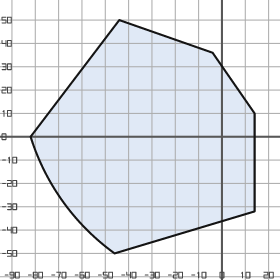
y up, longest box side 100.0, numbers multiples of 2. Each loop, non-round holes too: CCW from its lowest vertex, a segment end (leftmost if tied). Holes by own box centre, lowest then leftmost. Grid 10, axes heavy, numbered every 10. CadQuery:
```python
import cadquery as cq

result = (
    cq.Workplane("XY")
    .moveTo(-46.0, -50.0)
    .lineTo(14.0, -32.0)
    .lineTo(14.0, 10.0)
    .lineTo(-4.0, 36.0)
    .lineTo(-44.0, 50.0)
    .lineTo(-82.0, 0.0)
    .threePointArc((-68.0, -28.0), (-46.0, -50.0))
    .close()
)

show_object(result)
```